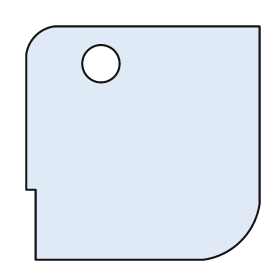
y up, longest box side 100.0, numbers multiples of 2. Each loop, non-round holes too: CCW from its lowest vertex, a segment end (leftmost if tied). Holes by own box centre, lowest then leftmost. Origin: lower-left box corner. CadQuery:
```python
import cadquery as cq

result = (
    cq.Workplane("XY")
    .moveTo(4.0, 0.0)
    .lineTo(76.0, 0.0)
    .threePointArc((92.0, 8.0), (100.0, 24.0))
    .lineTo(100.0, 100.0)
    .lineTo(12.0, 100.0)
    .threePointArc((4.0, 96.0), (0.0, 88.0))
    .lineTo(0.0, 30.0)
    .lineTo(4.0, 30.0)
    .close()
    .moveTo(32.0, 84.0)
    .circle(8.0)
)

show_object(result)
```